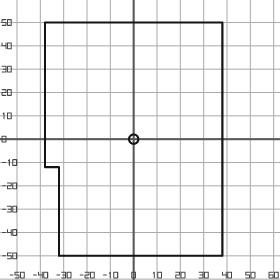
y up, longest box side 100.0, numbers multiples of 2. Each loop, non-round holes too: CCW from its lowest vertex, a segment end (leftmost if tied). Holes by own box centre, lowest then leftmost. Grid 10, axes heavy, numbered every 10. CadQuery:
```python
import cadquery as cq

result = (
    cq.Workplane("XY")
    .moveTo(-32.0, -50.0)
    .lineTo(38.0, -50.0)
    .lineTo(38.0, 50.0)
    .lineTo(-38.0, 50.0)
    .lineTo(-38.0, -12.0)
    .lineTo(-32.0, -12.0)
    .close()
    .moveTo(0.0, 0.0)
    .circle(2.0)
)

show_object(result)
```